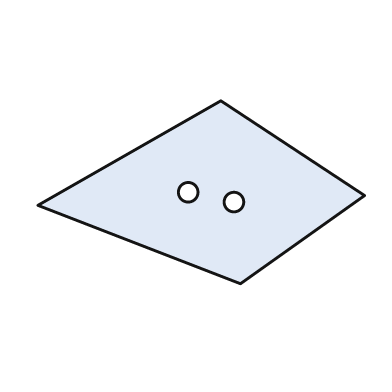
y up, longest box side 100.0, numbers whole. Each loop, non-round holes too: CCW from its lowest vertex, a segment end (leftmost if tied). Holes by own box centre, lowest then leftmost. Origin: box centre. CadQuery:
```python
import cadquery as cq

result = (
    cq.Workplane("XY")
    .moveTo(12.0, -28.0)
    .lineTo(50.0, -1.0)
    .lineTo(6.0, 28.0)
    .lineTo(-50.0, -4.0)
    .close()
    .moveTo(10.0, -3.0)
    .circle(3.0)
    .moveTo(-4.0, 0.0)
    .circle(3.0)
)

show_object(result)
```